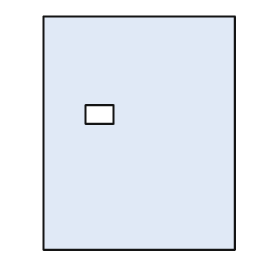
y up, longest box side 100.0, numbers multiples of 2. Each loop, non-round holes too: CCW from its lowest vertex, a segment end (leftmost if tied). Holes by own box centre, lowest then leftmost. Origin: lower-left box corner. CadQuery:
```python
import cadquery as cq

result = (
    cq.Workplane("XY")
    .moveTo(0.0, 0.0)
    .lineTo(82.0, 0.0)
    .lineTo(82.0, 100.0)
    .lineTo(0.0, 100.0)
    .close()
    .moveTo(18.0, 54.0)
    .lineTo(30.0, 54.0)
    .lineTo(30.0, 62.0)
    .lineTo(18.0, 62.0)
    .close()
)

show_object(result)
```